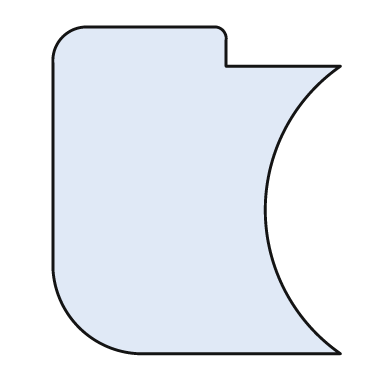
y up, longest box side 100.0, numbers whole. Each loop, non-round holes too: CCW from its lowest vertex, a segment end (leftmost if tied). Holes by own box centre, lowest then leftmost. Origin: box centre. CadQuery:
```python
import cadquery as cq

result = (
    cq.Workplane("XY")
    .moveTo(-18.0, -50.0)
    .lineTo(44.0, -50.0)
    .threePointArc((21.0, -6.0), (44.0, 38.0))
    .lineTo(9.0, 38.0)
    .lineTo(9.0, 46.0)
    .threePointArc((8.0, 49.0), (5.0, 50.0))
    .lineTo(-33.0, 50.0)
    .threePointArc((-41.0, 47.0), (-44.0, 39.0))
    .lineTo(-44.0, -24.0)
    .threePointArc((-36.0, -42.0), (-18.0, -50.0))
    .close()
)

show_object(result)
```